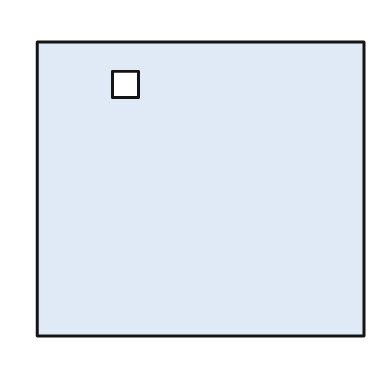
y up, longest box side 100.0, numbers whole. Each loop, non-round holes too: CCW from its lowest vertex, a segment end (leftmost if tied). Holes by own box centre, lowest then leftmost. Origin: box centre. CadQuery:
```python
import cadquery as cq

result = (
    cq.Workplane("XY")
    .moveTo(-50.0, -45.0)
    .lineTo(50.0, -45.0)
    .lineTo(50.0, 45.0)
    .lineTo(-50.0, 45.0)
    .close()
    .moveTo(-27.0, 28.0)
    .lineTo(-19.0, 28.0)
    .lineTo(-19.0, 36.0)
    .lineTo(-27.0, 36.0)
    .close()
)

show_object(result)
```